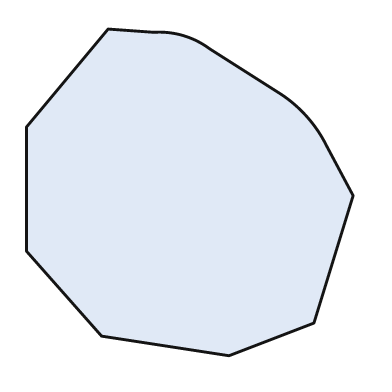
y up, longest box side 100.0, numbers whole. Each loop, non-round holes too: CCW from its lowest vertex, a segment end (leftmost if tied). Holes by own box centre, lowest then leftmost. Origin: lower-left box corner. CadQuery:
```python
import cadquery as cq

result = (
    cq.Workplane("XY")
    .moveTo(62.0, 0.0)
    .lineTo(88.0, 10.0)
    .lineTo(100.0, 49.0)
    .lineTo(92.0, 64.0)
    .threePointArc((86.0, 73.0), (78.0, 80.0))
    .lineTo(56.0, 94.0)
    .threePointArc((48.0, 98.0), (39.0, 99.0))
    .lineTo(25.0, 100.0)
    .lineTo(0.0, 70.0)
    .lineTo(0.0, 32.0)
    .lineTo(23.0, 6.0)
    .close()
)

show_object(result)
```